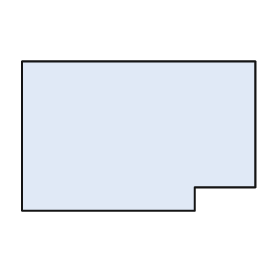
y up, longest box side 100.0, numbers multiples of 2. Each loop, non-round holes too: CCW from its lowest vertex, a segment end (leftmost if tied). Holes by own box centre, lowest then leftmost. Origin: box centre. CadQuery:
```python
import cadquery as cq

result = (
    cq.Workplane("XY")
    .moveTo(-50.0, -32.0)
    .lineTo(24.0, -32.0)
    .lineTo(24.0, -22.0)
    .lineTo(50.0, -22.0)
    .lineTo(50.0, 32.0)
    .lineTo(-50.0, 32.0)
    .close()
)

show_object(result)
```